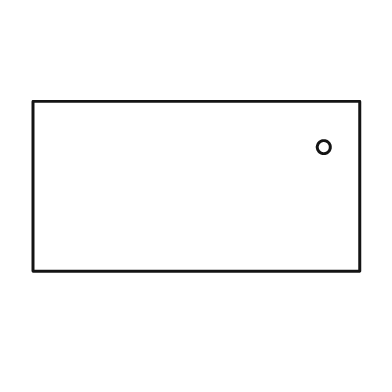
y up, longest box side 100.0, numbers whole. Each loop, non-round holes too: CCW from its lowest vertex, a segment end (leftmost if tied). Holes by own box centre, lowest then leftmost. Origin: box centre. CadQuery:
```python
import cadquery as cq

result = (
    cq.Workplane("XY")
    .moveTo(-50.0, -26.0)
    .lineTo(50.0, -26.0)
    .lineTo(50.0, 26.0)
    .lineTo(-50.0, 26.0)
    .close()
    .moveTo(39.0, 12.0)
    .circle(2.0)
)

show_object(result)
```